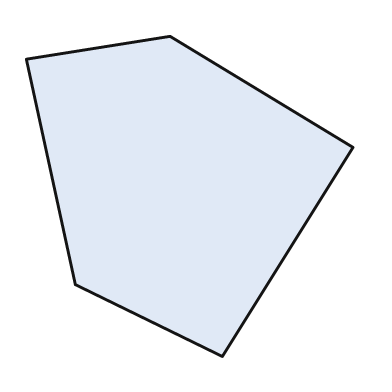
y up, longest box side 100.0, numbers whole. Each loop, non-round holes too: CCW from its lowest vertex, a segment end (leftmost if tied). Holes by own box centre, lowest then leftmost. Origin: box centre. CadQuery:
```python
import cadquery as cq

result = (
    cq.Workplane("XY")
    .moveTo(10.0, -49.0)
    .lineTo(50.0, 15.0)
    .lineTo(-6.0, 49.0)
    .lineTo(-50.0, 42.0)
    .lineTo(-35.0, -27.0)
    .close()
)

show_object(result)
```